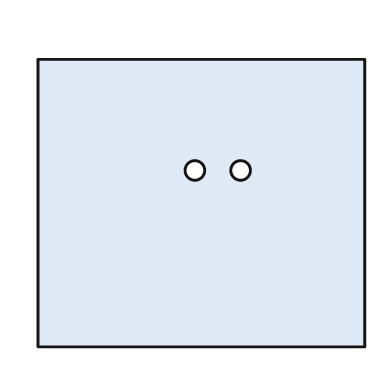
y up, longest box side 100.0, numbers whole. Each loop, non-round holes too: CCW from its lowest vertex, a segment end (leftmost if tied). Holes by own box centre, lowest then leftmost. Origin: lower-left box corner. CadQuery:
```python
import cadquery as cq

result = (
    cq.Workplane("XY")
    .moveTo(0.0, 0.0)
    .lineTo(100.0, 0.0)
    .lineTo(100.0, 88.0)
    .lineTo(0.0, 88.0)
    .close()
    .moveTo(48.0, 54.0)
    .circle(3.0)
    .moveTo(62.0, 54.0)
    .circle(3.0)
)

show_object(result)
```